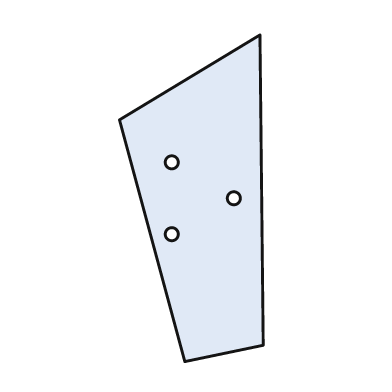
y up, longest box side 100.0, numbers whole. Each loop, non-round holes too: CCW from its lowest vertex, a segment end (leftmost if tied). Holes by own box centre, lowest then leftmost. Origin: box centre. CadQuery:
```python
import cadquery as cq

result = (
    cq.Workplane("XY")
    .moveTo(-2.0, -50.0)
    .lineTo(22.0, -45.0)
    .lineTo(21.0, 50.0)
    .lineTo(-22.0, 24.0)
    .close()
    .moveTo(-6.0, -11.0)
    .circle(2.0)
    .moveTo(13.0, 0.0)
    .circle(2.0)
    .moveTo(-6.0, 11.0)
    .circle(2.0)
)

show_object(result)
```